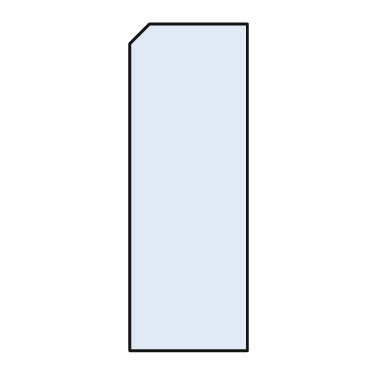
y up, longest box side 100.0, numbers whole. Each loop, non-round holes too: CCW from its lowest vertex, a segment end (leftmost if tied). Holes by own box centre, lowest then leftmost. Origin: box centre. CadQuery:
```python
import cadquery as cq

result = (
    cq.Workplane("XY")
    .moveTo(-18.0, -50.0)
    .lineTo(18.0, -50.0)
    .lineTo(18.0, 50.0)
    .lineTo(-12.0, 50.0)
    .lineTo(-18.0, 44.0)
    .close()
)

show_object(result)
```